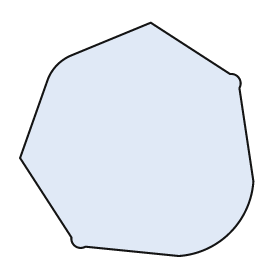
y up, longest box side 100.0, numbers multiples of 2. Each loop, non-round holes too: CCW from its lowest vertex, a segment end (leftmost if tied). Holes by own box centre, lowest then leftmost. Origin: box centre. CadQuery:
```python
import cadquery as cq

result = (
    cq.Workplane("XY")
    .moveTo(18.0, -50.0)
    .threePointArc((40.0, -40.0), (50.0, -18.0))
    .lineTo(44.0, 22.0)
    .threePointArc((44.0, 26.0), (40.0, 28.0))
    .lineTo(6.0, 50.0)
    .lineTo(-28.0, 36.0)
    .threePointArc((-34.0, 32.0), (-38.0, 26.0))
    .lineTo(-50.0, -8.0)
    .lineTo(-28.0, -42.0)
    .threePointArc((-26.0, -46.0), (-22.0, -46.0))
    .close()
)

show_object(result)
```